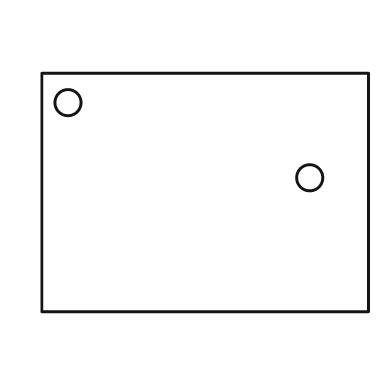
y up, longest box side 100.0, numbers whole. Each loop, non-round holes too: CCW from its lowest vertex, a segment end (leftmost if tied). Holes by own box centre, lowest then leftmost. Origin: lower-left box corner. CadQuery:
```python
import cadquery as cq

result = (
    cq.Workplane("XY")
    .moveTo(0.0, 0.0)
    .lineTo(100.0, 0.0)
    .lineTo(100.0, 73.0)
    .lineTo(0.0, 73.0)
    .close()
    .moveTo(82.0, 41.0)
    .circle(4.0)
    .moveTo(8.0, 64.0)
    .circle(4.0)
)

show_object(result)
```